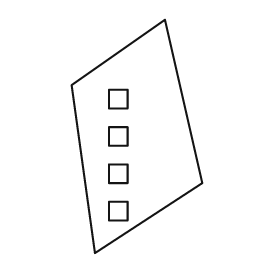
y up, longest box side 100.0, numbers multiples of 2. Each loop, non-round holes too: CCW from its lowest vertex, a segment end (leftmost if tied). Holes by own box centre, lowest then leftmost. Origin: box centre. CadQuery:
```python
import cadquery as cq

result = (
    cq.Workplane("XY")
    .moveTo(-18.0, -50.0)
    .lineTo(28.0, -20.0)
    .lineTo(12.0, 50.0)
    .lineTo(-28.0, 22.0)
    .close()
    .moveTo(-12.0, -36.0)
    .lineTo(-4.0, -36.0)
    .lineTo(-4.0, -28.0)
    .lineTo(-12.0, -28.0)
    .close()
    .moveTo(-12.0, -20.0)
    .lineTo(-4.0, -20.0)
    .lineTo(-4.0, -12.0)
    .lineTo(-12.0, -12.0)
    .close()
    .moveTo(-12.0, -4.0)
    .lineTo(-4.0, -4.0)
    .lineTo(-4.0, 4.0)
    .lineTo(-12.0, 4.0)
    .close()
    .moveTo(-12.0, 12.0)
    .lineTo(-4.0, 12.0)
    .lineTo(-4.0, 20.0)
    .lineTo(-12.0, 20.0)
    .close()
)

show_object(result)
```